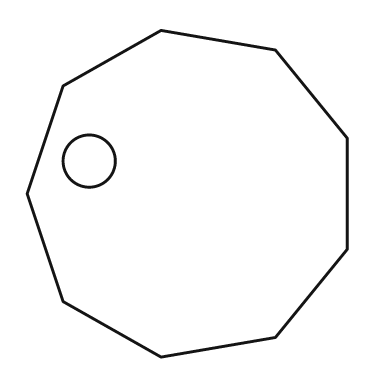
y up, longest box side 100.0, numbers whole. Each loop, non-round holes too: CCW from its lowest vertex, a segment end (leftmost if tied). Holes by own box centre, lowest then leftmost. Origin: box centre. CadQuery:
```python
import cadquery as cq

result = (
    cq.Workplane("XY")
    .moveTo(-8.0, -50.0)
    .lineTo(27.0, -44.0)
    .lineTo(49.0, -17.0)
    .lineTo(49.0, 17.0)
    .lineTo(27.0, 44.0)
    .lineTo(-8.0, 50.0)
    .lineTo(-38.0, 33.0)
    .lineTo(-49.0, 0.0)
    .lineTo(-38.0, -33.0)
    .close()
    .moveTo(-30.0, 10.0)
    .circle(8.0)
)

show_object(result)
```